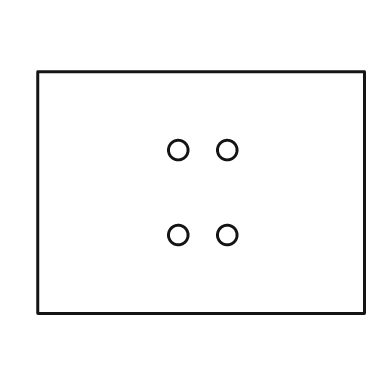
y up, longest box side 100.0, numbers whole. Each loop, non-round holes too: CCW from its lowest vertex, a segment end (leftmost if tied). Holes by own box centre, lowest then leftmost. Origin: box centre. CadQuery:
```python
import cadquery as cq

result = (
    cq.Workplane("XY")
    .moveTo(-50.0, -37.0)
    .lineTo(50.0, -37.0)
    .lineTo(50.0, 37.0)
    .lineTo(-50.0, 37.0)
    .close()
    .moveTo(-7.0, -13.0)
    .circle(3.0)
    .moveTo(8.0, -13.0)
    .circle(3.0)
    .moveTo(-7.0, 13.0)
    .circle(3.0)
    .moveTo(8.0, 13.0)
    .circle(3.0)
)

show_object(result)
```